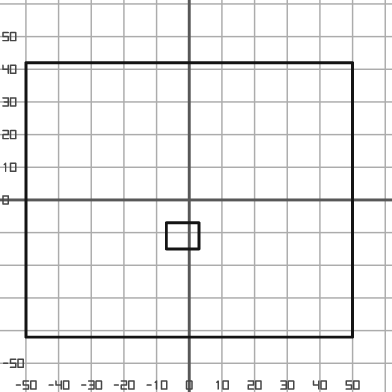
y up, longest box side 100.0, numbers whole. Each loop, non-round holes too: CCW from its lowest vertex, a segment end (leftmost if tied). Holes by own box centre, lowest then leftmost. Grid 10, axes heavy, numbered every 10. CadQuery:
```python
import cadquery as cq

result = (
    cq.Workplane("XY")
    .moveTo(-50.0, -42.0)
    .lineTo(50.0, -42.0)
    .lineTo(50.0, 42.0)
    .lineTo(-50.0, 42.0)
    .close()
    .moveTo(-7.0, -15.0)
    .lineTo(3.0, -15.0)
    .lineTo(3.0, -7.0)
    .lineTo(-7.0, -7.0)
    .close()
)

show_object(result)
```